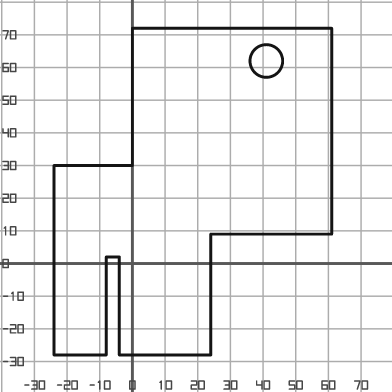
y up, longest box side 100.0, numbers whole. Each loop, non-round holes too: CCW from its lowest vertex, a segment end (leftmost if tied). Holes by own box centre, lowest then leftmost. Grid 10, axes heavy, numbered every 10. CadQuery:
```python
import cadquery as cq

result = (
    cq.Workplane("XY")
    .moveTo(-24.0, -28.0)
    .lineTo(-8.0, -28.0)
    .lineTo(-8.0, 2.0)
    .lineTo(-4.0, 2.0)
    .lineTo(-4.0, -28.0)
    .lineTo(24.0, -28.0)
    .lineTo(24.0, 9.0)
    .lineTo(61.0, 9.0)
    .lineTo(61.0, 72.0)
    .lineTo(0.0, 72.0)
    .lineTo(0.0, 30.0)
    .lineTo(-24.0, 30.0)
    .close()
    .moveTo(41.0, 62.0)
    .circle(5.0)
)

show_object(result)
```